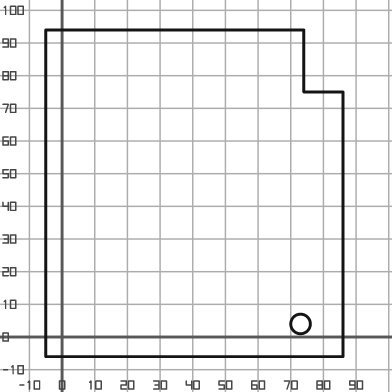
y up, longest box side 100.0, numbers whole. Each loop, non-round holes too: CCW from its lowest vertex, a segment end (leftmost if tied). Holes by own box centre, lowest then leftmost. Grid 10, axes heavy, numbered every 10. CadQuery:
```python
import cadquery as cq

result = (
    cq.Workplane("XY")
    .moveTo(-5.0, -6.0)
    .lineTo(86.0, -6.0)
    .lineTo(86.0, 75.0)
    .lineTo(74.0, 75.0)
    .lineTo(74.0, 94.0)
    .lineTo(-5.0, 94.0)
    .close()
    .moveTo(73.0, 4.0)
    .circle(3.0)
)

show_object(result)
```